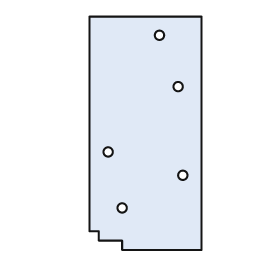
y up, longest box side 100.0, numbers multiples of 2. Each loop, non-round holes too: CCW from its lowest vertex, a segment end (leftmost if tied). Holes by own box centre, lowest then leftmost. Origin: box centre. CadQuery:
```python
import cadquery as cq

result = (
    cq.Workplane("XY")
    .moveTo(-10.0, -50.0)
    .lineTo(24.0, -50.0)
    .lineTo(24.0, 50.0)
    .lineTo(-24.0, 50.0)
    .lineTo(-24.0, -42.0)
    .lineTo(-20.0, -42.0)
    .lineTo(-20.0, -46.0)
    .lineTo(-10.0, -46.0)
    .close()
    .moveTo(-10.0, -32.0)
    .circle(2.0)
    .moveTo(16.0, -18.0)
    .circle(2.0)
    .moveTo(-16.0, -8.0)
    .circle(2.0)
    .moveTo(14.0, 20.0)
    .circle(2.0)
    .moveTo(6.0, 42.0)
    .circle(2.0)
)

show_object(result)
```